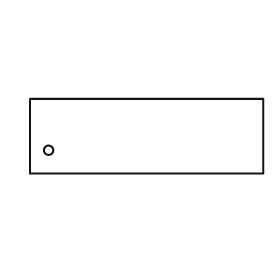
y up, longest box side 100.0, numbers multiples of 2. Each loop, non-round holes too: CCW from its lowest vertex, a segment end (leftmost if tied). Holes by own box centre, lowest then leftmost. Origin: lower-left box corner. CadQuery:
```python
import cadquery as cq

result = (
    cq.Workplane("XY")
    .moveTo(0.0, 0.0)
    .lineTo(100.0, 0.0)
    .lineTo(100.0, 32.0)
    .lineTo(0.0, 32.0)
    .close()
    .moveTo(8.0, 10.0)
    .circle(2.0)
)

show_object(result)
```